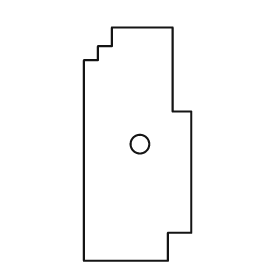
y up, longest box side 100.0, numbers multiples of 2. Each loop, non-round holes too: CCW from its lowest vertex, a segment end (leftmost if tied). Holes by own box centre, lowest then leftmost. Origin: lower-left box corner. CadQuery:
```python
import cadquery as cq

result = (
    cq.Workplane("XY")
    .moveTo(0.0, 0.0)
    .lineTo(36.0, 0.0)
    .lineTo(36.0, 12.0)
    .lineTo(46.0, 12.0)
    .lineTo(46.0, 64.0)
    .lineTo(38.0, 64.0)
    .lineTo(38.0, 100.0)
    .lineTo(12.0, 100.0)
    .lineTo(12.0, 92.0)
    .lineTo(6.0, 92.0)
    .lineTo(6.0, 86.0)
    .lineTo(0.0, 86.0)
    .close()
    .moveTo(24.0, 50.0)
    .circle(4.0)
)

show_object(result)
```